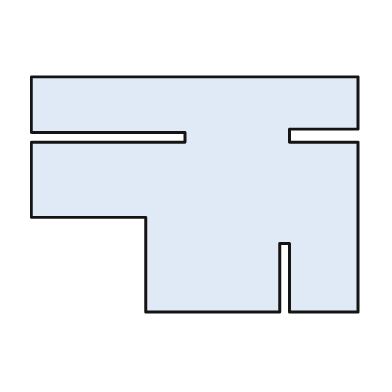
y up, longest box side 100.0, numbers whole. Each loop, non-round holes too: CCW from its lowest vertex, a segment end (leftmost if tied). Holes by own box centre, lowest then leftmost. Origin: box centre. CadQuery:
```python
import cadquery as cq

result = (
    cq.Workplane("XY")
    .moveTo(-15.0, -36.0)
    .lineTo(26.0, -36.0)
    .lineTo(26.0, -15.0)
    .lineTo(29.0, -15.0)
    .lineTo(29.0, -36.0)
    .lineTo(50.0, -36.0)
    .lineTo(50.0, 16.0)
    .lineTo(29.0, 16.0)
    .lineTo(29.0, 20.0)
    .lineTo(50.0, 20.0)
    .lineTo(50.0, 36.0)
    .lineTo(-50.0, 36.0)
    .lineTo(-50.0, 19.0)
    .lineTo(-3.0, 19.0)
    .lineTo(-3.0, 16.0)
    .lineTo(-50.0, 16.0)
    .lineTo(-50.0, -7.0)
    .lineTo(-15.0, -7.0)
    .close()
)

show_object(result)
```